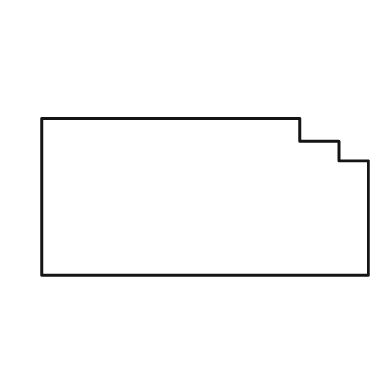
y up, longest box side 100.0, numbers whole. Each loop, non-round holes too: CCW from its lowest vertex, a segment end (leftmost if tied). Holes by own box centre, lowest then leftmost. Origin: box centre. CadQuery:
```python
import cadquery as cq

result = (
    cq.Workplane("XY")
    .moveTo(-50.0, -24.0)
    .lineTo(50.0, -24.0)
    .lineTo(50.0, 11.0)
    .lineTo(41.0, 11.0)
    .lineTo(41.0, 17.0)
    .lineTo(29.0, 17.0)
    .lineTo(29.0, 24.0)
    .lineTo(-50.0, 24.0)
    .close()
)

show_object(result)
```